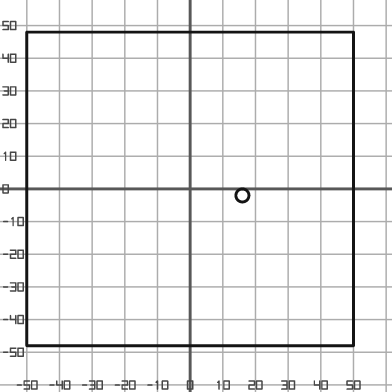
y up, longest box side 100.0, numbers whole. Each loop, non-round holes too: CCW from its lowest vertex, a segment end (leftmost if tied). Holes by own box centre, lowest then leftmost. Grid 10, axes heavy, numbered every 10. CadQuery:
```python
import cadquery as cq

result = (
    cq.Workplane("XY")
    .moveTo(-50.0, -48.0)
    .lineTo(50.0, -48.0)
    .lineTo(50.0, 48.0)
    .lineTo(-50.0, 48.0)
    .close()
    .moveTo(16.0, -2.0)
    .circle(2.0)
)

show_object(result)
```